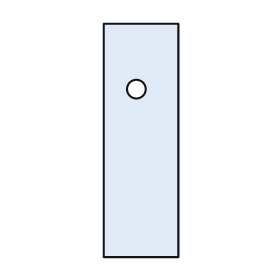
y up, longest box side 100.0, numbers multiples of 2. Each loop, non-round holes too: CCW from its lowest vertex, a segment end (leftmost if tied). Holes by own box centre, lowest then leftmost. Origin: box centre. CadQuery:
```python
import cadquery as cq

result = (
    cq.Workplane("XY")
    .moveTo(-16.0, -50.0)
    .lineTo(16.0, -50.0)
    .lineTo(16.0, 50.0)
    .lineTo(-16.0, 50.0)
    .close()
    .moveTo(-2.0, 22.0)
    .circle(4.0)
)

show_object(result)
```